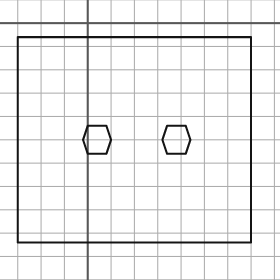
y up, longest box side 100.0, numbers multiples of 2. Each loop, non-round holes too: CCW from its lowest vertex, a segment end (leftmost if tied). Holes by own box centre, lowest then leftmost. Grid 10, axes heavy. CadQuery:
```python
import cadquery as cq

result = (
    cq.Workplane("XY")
    .moveTo(-30.0, -94.0)
    .lineTo(70.0, -94.0)
    .lineTo(70.0, -6.0)
    .lineTo(-30.0, -6.0)
    .close()
    .moveTo(0.0, -56.0)
    .lineTo(8.0, -56.0)
    .lineTo(10.0, -50.0)
    .lineTo(8.0, -44.0)
    .lineTo(0.0, -44.0)
    .lineTo(-2.0, -50.0)
    .close()
    .moveTo(34.0, -56.0)
    .lineTo(42.0, -56.0)
    .lineTo(44.0, -50.0)
    .lineTo(42.0, -44.0)
    .lineTo(34.0, -44.0)
    .lineTo(32.0, -50.0)
    .close()
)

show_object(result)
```